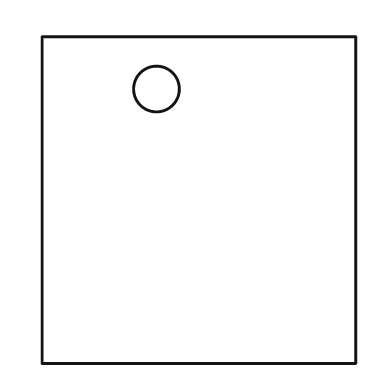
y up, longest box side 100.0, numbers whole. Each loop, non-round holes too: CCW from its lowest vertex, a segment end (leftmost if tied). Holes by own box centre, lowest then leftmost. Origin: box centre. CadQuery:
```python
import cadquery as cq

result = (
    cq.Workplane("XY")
    .moveTo(-48.0, -50.0)
    .lineTo(48.0, -50.0)
    .lineTo(48.0, 50.0)
    .lineTo(-48.0, 50.0)
    .close()
    .moveTo(-13.0, 34.0)
    .circle(7.0)
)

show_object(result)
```